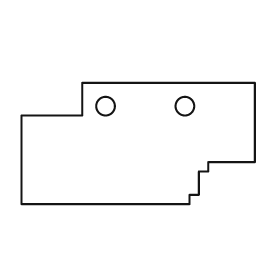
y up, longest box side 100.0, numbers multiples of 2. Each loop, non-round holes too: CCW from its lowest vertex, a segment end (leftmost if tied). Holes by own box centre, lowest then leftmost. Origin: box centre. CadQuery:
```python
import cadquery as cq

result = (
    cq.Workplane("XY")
    .moveTo(-50.0, -26.0)
    .lineTo(22.0, -26.0)
    .lineTo(22.0, -22.0)
    .lineTo(26.0, -22.0)
    .lineTo(26.0, -12.0)
    .lineTo(30.0, -12.0)
    .lineTo(30.0, -8.0)
    .lineTo(50.0, -8.0)
    .lineTo(50.0, 26.0)
    .lineTo(-24.0, 26.0)
    .lineTo(-24.0, 12.0)
    .lineTo(-50.0, 12.0)
    .close()
    .moveTo(-14.0, 16.0)
    .circle(4.0)
    .moveTo(20.0, 16.0)
    .circle(4.0)
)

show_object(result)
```